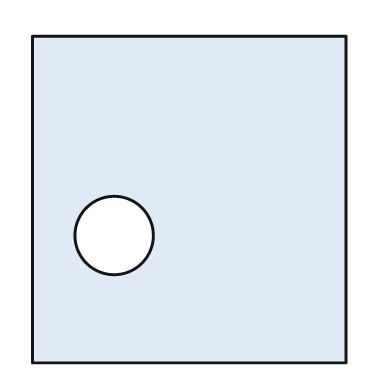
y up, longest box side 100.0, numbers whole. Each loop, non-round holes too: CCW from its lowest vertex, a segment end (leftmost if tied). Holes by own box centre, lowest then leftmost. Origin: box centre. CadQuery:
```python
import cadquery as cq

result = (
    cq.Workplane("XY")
    .moveTo(-48.0, -50.0)
    .lineTo(48.0, -50.0)
    .lineTo(48.0, 50.0)
    .lineTo(-48.0, 50.0)
    .close()
    .moveTo(-23.0, -11.0)
    .circle(12.0)
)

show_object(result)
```